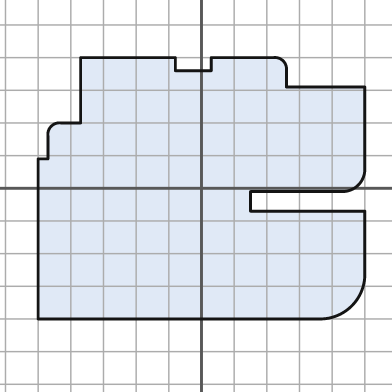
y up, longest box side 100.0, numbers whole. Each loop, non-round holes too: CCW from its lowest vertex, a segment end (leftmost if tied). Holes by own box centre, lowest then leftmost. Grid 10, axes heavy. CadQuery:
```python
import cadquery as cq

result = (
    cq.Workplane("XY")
    .moveTo(-50.0, -40.0)
    .lineTo(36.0, -40.0)
    .threePointArc((46.0, -36.0), (50.0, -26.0))
    .lineTo(50.0, -7.0)
    .lineTo(15.0, -7.0)
    .lineTo(15.0, -1.0)
    .lineTo(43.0, -1.0)
    .threePointArc((48.0, 1.0), (50.0, 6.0))
    .lineTo(50.0, 31.0)
    .lineTo(26.0, 31.0)
    .lineTo(26.0, 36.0)
    .threePointArc((25.0, 39.0), (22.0, 40.0))
    .lineTo(3.0, 40.0)
    .lineTo(3.0, 36.0)
    .lineTo(-8.0, 36.0)
    .lineTo(-8.0, 40.0)
    .lineTo(-37.0, 40.0)
    .lineTo(-37.0, 20.0)
    .lineTo(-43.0, 20.0)
    .threePointArc((-46.0, 19.0), (-47.0, 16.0))
    .lineTo(-47.0, 9.0)
    .lineTo(-50.0, 9.0)
    .close()
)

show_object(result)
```